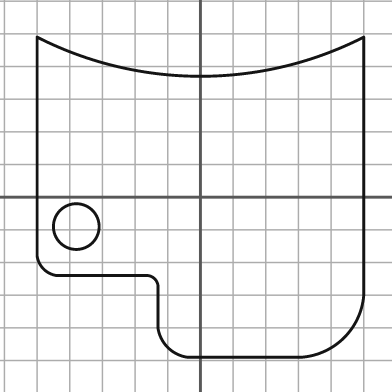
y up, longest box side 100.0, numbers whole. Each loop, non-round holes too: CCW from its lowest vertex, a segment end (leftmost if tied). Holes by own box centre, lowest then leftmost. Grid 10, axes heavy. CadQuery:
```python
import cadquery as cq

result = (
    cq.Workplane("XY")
    .moveTo(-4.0, -49.0)
    .lineTo(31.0, -49.0)
    .threePointArc((44.0, -43.0), (50.0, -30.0))
    .lineTo(50.0, 49.0)
    .threePointArc((0.0, 37.0), (-50.0, 49.0))
    .lineTo(-50.0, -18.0)
    .threePointArc((-48.0, -22.0), (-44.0, -24.0))
    .lineTo(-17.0, -24.0)
    .threePointArc((-14.0, -25.0), (-13.0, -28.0))
    .lineTo(-13.0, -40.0)
    .threePointArc((-10.0, -46.0), (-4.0, -49.0))
    .close()
    .moveTo(-38.0, -9.0)
    .circle(7.0)
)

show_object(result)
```